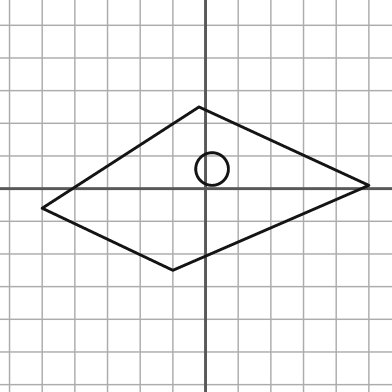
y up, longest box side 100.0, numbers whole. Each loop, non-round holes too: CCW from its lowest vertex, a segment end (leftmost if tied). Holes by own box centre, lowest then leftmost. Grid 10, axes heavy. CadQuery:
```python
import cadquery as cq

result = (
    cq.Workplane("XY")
    .moveTo(-10.0, -25.0)
    .lineTo(50.0, 1.0)
    .lineTo(-2.0, 25.0)
    .lineTo(-50.0, -6.0)
    .close()
    .moveTo(2.0, 6.0)
    .circle(5.0)
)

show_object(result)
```